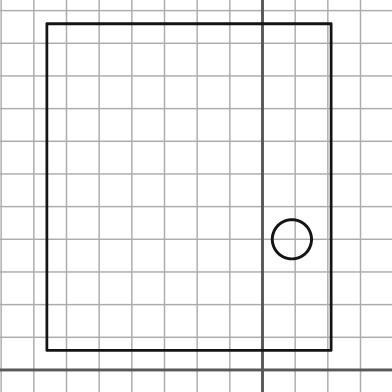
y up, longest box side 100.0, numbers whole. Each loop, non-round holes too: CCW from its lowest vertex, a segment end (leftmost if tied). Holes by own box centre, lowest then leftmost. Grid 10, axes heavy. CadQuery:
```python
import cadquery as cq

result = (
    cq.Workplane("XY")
    .moveTo(-66.0, 6.0)
    .lineTo(21.0, 6.0)
    .lineTo(21.0, 106.0)
    .lineTo(-66.0, 106.0)
    .close()
    .moveTo(9.0, 40.0)
    .circle(6.0)
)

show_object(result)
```